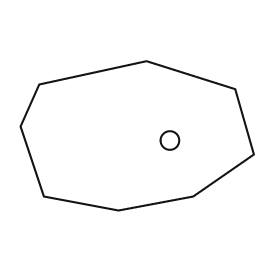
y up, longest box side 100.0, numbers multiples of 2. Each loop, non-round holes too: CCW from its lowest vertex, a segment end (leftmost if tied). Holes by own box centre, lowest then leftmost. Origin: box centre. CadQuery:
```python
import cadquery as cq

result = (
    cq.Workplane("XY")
    .moveTo(-8.0, -32.0)
    .lineTo(24.0, -26.0)
    .lineTo(50.0, -8.0)
    .lineTo(42.0, 20.0)
    .lineTo(4.0, 32.0)
    .lineTo(-42.0, 22.0)
    .lineTo(-50.0, 4.0)
    .lineTo(-40.0, -26.0)
    .close()
    .moveTo(14.0, -2.0)
    .circle(4.0)
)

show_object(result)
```